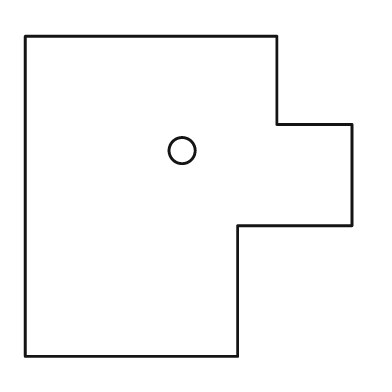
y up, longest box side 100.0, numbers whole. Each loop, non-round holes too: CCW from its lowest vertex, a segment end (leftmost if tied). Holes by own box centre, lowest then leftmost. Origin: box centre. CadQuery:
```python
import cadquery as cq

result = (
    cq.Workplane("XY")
    .moveTo(-50.0, -49.0)
    .lineTo(15.0, -49.0)
    .lineTo(15.0, -9.0)
    .lineTo(50.0, -9.0)
    .lineTo(50.0, 22.0)
    .lineTo(27.0, 22.0)
    .lineTo(27.0, 49.0)
    .lineTo(-50.0, 49.0)
    .close()
    .moveTo(-2.0, 14.0)
    .circle(4.0)
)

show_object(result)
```